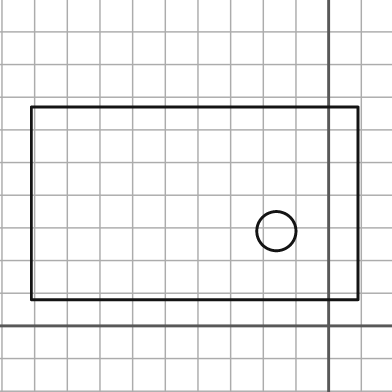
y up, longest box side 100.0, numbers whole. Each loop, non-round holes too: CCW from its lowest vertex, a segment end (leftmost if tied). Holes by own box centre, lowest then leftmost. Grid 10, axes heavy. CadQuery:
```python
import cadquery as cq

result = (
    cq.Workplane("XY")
    .moveTo(-91.0, 8.0)
    .lineTo(9.0, 8.0)
    .lineTo(9.0, 67.0)
    .lineTo(-91.0, 67.0)
    .close()
    .moveTo(-16.0, 29.0)
    .circle(6.0)
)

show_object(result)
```